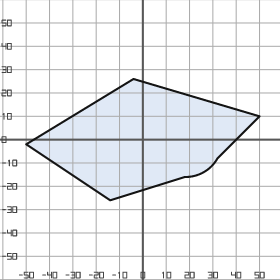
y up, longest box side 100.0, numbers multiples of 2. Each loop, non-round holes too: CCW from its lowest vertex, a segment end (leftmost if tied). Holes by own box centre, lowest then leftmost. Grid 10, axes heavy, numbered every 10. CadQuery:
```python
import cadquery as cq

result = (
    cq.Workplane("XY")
    .moveTo(-14.0, -26.0)
    .lineTo(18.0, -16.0)
    .threePointArc((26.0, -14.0), (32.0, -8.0))
    .lineTo(50.0, 10.0)
    .lineTo(-4.0, 26.0)
    .lineTo(-50.0, -2.0)
    .close()
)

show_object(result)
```